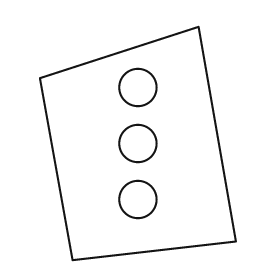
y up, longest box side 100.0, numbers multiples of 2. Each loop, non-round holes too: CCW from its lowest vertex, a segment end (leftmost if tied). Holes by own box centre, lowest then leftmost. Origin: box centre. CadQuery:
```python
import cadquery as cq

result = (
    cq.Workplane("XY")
    .moveTo(-28.0, -50.0)
    .lineTo(42.0, -42.0)
    .lineTo(26.0, 50.0)
    .lineTo(-42.0, 28.0)
    .close()
    .moveTo(0.0, -24.0)
    .circle(8.0)
    .moveTo(0.0, 0.0)
    .circle(8.0)
    .moveTo(0.0, 24.0)
    .circle(8.0)
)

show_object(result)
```